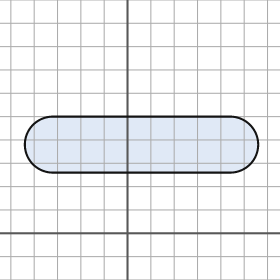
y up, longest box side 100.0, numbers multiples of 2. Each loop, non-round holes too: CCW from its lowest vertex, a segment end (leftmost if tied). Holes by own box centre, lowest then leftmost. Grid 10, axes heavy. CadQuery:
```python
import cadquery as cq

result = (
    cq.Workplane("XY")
    .moveTo(-32.0, 26.0)
    .lineTo(44.0, 26.0)
    .threePointArc((56.0, 38.0), (44.0, 50.0))
    .lineTo(-32.0, 50.0)
    .threePointArc((-44.0, 38.0), (-32.0, 26.0))
    .close()
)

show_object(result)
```